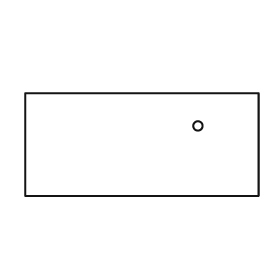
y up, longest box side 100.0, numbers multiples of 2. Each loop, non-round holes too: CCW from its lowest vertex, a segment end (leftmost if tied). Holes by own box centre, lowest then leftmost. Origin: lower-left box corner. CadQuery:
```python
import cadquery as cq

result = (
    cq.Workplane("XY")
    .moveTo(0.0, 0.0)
    .lineTo(100.0, 0.0)
    .lineTo(100.0, 44.0)
    .lineTo(0.0, 44.0)
    .close()
    .moveTo(74.0, 30.0)
    .circle(2.0)
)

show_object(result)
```